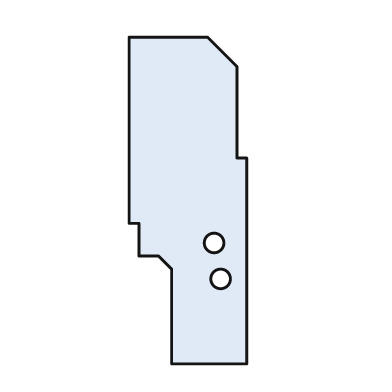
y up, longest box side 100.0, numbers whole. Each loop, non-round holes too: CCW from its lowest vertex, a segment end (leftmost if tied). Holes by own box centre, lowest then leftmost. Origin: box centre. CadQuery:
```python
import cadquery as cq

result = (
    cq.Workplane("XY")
    .moveTo(-5.0, -50.0)
    .lineTo(18.0, -50.0)
    .lineTo(18.0, 13.0)
    .lineTo(15.0, 13.0)
    .lineTo(15.0, 41.0)
    .lineTo(6.0, 50.0)
    .lineTo(-18.0, 50.0)
    .lineTo(-18.0, -7.0)
    .lineTo(-15.0, -7.0)
    .lineTo(-15.0, -17.0)
    .lineTo(-9.0, -17.0)
    .lineTo(-5.0, -21.0)
    .close()
    .moveTo(10.0, -24.0)
    .circle(3.0)
    .moveTo(8.0, -13.0)
    .circle(3.0)
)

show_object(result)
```